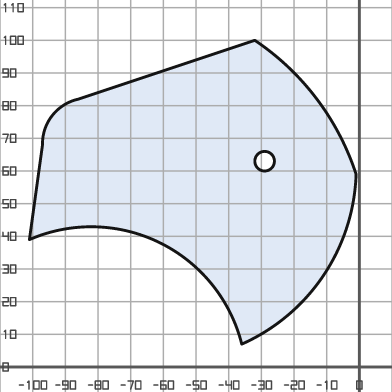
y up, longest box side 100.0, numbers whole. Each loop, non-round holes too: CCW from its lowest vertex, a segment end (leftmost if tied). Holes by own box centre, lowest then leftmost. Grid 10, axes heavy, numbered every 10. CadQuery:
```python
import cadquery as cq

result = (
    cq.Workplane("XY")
    .moveTo(-36.0, 7.0)
    .threePointArc((-11.0, 28.0), (-1.0, 59.0))
    .threePointArc((-13.0, 82.0), (-32.0, 100.0))
    .lineTo(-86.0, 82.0)
    .threePointArc((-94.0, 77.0), (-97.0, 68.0))
    .lineTo(-101.0, 39.0)
    .threePointArc((-61.0, 38.0), (-36.0, 7.0))
    .close()
    .moveTo(-29.0, 63.0)
    .circle(3.0)
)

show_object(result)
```